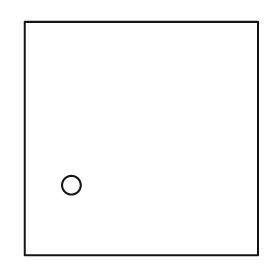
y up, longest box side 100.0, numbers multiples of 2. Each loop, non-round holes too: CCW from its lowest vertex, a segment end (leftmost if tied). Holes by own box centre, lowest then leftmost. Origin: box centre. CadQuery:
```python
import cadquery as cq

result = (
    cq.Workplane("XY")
    .moveTo(-50.0, -50.0)
    .lineTo(50.0, -50.0)
    .lineTo(50.0, 50.0)
    .lineTo(-50.0, 50.0)
    .close()
    .moveTo(-30.0, -20.0)
    .circle(4.0)
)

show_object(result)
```